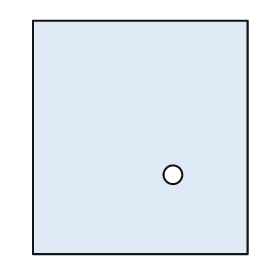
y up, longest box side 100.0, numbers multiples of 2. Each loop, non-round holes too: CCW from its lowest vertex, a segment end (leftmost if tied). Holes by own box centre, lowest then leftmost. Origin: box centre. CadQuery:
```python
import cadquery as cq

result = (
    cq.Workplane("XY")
    .moveTo(-46.0, -50.0)
    .lineTo(46.0, -50.0)
    .lineTo(46.0, 50.0)
    .lineTo(-46.0, 50.0)
    .close()
    .moveTo(14.0, -16.0)
    .circle(4.0)
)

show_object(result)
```